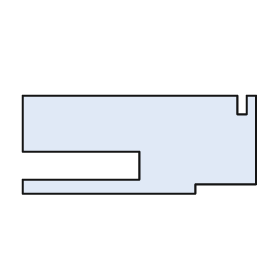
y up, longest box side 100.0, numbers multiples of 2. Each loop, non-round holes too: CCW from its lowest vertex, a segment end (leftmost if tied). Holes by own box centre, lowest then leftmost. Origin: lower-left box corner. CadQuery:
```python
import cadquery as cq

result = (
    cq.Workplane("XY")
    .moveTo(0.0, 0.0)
    .lineTo(74.0, 0.0)
    .lineTo(74.0, 4.0)
    .lineTo(100.0, 4.0)
    .lineTo(100.0, 42.0)
    .lineTo(96.0, 42.0)
    .lineTo(96.0, 34.0)
    .lineTo(92.0, 34.0)
    .lineTo(92.0, 42.0)
    .lineTo(0.0, 42.0)
    .lineTo(0.0, 18.0)
    .lineTo(50.0, 18.0)
    .lineTo(50.0, 6.0)
    .lineTo(0.0, 6.0)
    .close()
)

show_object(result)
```